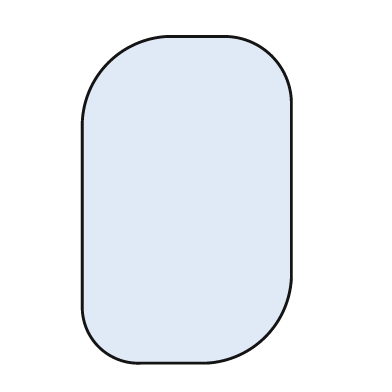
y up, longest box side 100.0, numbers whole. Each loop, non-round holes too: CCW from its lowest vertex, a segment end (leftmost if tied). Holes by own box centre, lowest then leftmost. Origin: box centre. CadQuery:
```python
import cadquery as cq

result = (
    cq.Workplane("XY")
    .moveTo(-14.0, -50.0)
    .lineTo(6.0, -50.0)
    .threePointArc((24.0, -42.0), (32.0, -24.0))
    .lineTo(32.0, 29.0)
    .threePointArc((26.0, 44.0), (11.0, 50.0))
    .lineTo(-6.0, 50.0)
    .threePointArc((-24.0, 42.0), (-32.0, 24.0))
    .lineTo(-32.0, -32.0)
    .threePointArc((-27.0, -45.0), (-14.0, -50.0))
    .close()
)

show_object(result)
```